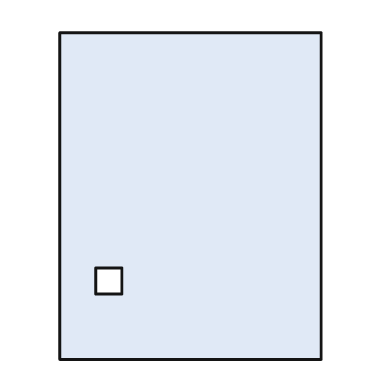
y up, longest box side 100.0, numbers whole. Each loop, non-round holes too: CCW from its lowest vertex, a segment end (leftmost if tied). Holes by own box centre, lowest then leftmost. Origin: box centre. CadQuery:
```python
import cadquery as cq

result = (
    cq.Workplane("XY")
    .moveTo(-40.0, -50.0)
    .lineTo(40.0, -50.0)
    .lineTo(40.0, 50.0)
    .lineTo(-40.0, 50.0)
    .close()
    .moveTo(-29.0, -30.0)
    .lineTo(-21.0, -30.0)
    .lineTo(-21.0, -22.0)
    .lineTo(-29.0, -22.0)
    .close()
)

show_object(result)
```